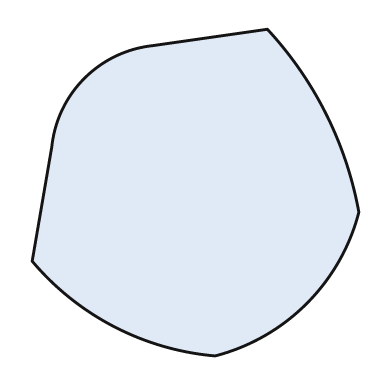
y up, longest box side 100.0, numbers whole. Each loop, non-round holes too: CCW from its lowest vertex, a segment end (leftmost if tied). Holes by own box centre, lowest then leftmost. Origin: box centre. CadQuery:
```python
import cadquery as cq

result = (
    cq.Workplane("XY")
    .moveTo(6.0, -50.0)
    .threePointArc((34.0, -34.0), (50.0, -6.0))
    .threePointArc((40.0, 24.0), (22.0, 50.0))
    .lineTo(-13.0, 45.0)
    .threePointArc((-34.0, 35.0), (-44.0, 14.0))
    .lineTo(-50.0, -21.0)
    .threePointArc((-25.0, -41.0), (6.0, -50.0))
    .close()
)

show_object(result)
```